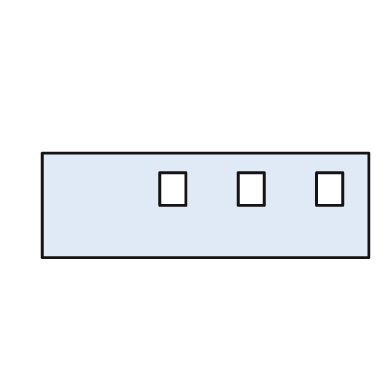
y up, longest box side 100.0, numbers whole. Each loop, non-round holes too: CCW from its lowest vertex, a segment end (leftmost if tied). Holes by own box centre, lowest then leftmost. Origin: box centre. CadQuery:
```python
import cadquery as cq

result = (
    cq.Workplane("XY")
    .moveTo(-50.0, -16.0)
    .lineTo(50.0, -16.0)
    .lineTo(50.0, 16.0)
    .lineTo(-50.0, 16.0)
    .close()
    .moveTo(-14.0, 0.0)
    .lineTo(-6.0, 0.0)
    .lineTo(-6.0, 10.0)
    .lineTo(-14.0, 10.0)
    .close()
    .moveTo(10.0, 0.0)
    .lineTo(18.0, 0.0)
    .lineTo(18.0, 10.0)
    .lineTo(10.0, 10.0)
    .close()
    .moveTo(34.0, 0.0)
    .lineTo(42.0, 0.0)
    .lineTo(42.0, 10.0)
    .lineTo(34.0, 10.0)
    .close()
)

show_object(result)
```